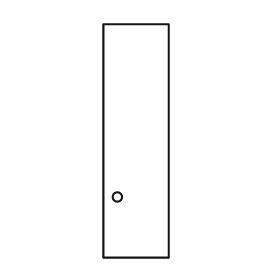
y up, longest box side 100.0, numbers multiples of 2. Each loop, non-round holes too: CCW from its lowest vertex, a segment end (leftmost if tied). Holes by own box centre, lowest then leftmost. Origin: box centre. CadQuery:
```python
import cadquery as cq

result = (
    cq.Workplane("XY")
    .moveTo(-14.0, -50.0)
    .lineTo(14.0, -50.0)
    .lineTo(14.0, 50.0)
    .lineTo(-14.0, 50.0)
    .close()
    .moveTo(-8.0, -24.0)
    .circle(2.0)
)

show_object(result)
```